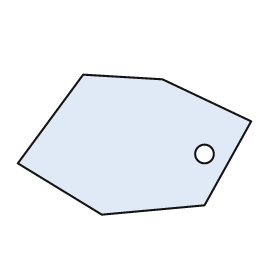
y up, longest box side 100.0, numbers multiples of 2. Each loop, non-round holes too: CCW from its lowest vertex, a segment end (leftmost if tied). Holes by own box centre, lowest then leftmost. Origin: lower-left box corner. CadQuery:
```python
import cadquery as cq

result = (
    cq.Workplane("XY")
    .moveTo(36.0, 0.0)
    .lineTo(80.0, 4.0)
    .lineTo(100.0, 40.0)
    .lineTo(62.0, 58.0)
    .lineTo(28.0, 60.0)
    .lineTo(0.0, 22.0)
    .close()
    .moveTo(80.0, 26.0)
    .circle(4.0)
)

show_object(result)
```